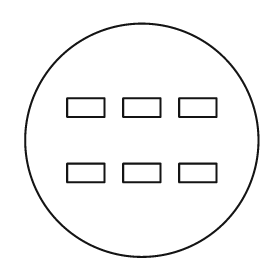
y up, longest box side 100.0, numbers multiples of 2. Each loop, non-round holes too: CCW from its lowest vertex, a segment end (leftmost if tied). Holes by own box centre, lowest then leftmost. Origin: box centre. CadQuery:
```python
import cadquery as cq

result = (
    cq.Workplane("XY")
    .moveTo(0.0, 0.0)
    .circle(50.0)
    .moveTo(-32.0, -18.0)
    .lineTo(-16.0, -18.0)
    .lineTo(-16.0, -10.0)
    .lineTo(-32.0, -10.0)
    .close()
    .moveTo(-8.0, -18.0)
    .lineTo(8.0, -18.0)
    .lineTo(8.0, -10.0)
    .lineTo(-8.0, -10.0)
    .close()
    .moveTo(16.0, -18.0)
    .lineTo(32.0, -18.0)
    .lineTo(32.0, -10.0)
    .lineTo(16.0, -10.0)
    .close()
    .moveTo(-32.0, 10.0)
    .lineTo(-16.0, 10.0)
    .lineTo(-16.0, 18.0)
    .lineTo(-32.0, 18.0)
    .close()
    .moveTo(-8.0, 10.0)
    .lineTo(8.0, 10.0)
    .lineTo(8.0, 18.0)
    .lineTo(-8.0, 18.0)
    .close()
    .moveTo(16.0, 10.0)
    .lineTo(32.0, 10.0)
    .lineTo(32.0, 18.0)
    .lineTo(16.0, 18.0)
    .close()
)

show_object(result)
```